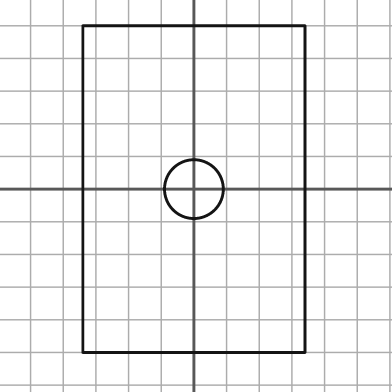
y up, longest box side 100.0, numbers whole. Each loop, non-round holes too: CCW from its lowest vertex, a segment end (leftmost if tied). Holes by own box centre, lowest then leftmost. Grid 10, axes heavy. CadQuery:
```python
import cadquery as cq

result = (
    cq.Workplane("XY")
    .moveTo(-34.0, -50.0)
    .lineTo(34.0, -50.0)
    .lineTo(34.0, 50.0)
    .lineTo(-34.0, 50.0)
    .close()
    .moveTo(0.0, 0.0)
    .circle(9.0)
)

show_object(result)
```